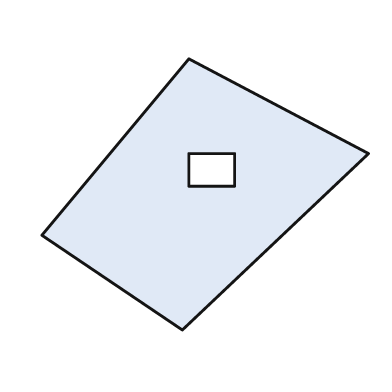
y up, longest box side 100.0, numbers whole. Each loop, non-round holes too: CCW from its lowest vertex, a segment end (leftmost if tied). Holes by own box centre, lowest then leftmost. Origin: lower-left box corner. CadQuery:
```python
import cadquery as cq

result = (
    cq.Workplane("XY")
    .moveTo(43.0, 0.0)
    .lineTo(100.0, 54.0)
    .lineTo(45.0, 83.0)
    .lineTo(0.0, 29.0)
    .close()
    .moveTo(45.0, 44.0)
    .lineTo(59.0, 44.0)
    .lineTo(59.0, 54.0)
    .lineTo(45.0, 54.0)
    .close()
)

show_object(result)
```